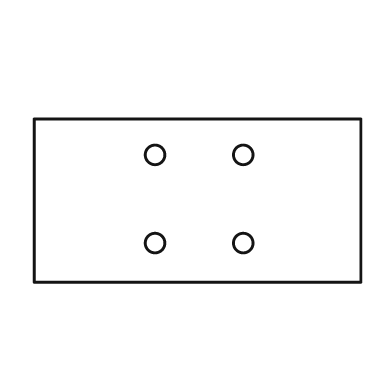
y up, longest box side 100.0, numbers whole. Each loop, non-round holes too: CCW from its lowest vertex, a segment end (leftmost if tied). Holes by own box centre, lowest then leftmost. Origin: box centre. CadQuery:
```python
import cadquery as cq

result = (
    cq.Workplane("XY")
    .moveTo(-50.0, -25.0)
    .lineTo(50.0, -25.0)
    .lineTo(50.0, 25.0)
    .lineTo(-50.0, 25.0)
    .close()
    .moveTo(-13.0, -13.0)
    .circle(3.0)
    .moveTo(14.0, -13.0)
    .circle(3.0)
    .moveTo(-13.0, 14.0)
    .circle(3.0)
    .moveTo(14.0, 14.0)
    .circle(3.0)
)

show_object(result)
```